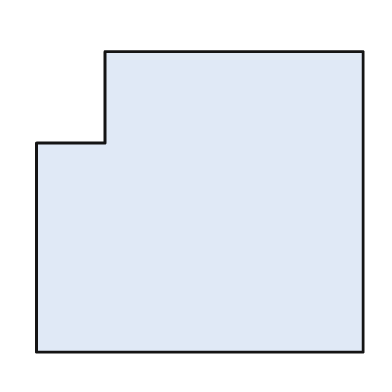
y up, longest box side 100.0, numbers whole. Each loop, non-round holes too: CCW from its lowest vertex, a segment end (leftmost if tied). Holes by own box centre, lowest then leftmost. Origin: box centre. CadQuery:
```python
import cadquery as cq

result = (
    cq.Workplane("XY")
    .moveTo(-50.0, -46.0)
    .lineTo(50.0, -46.0)
    .lineTo(50.0, 46.0)
    .lineTo(-29.0, 46.0)
    .lineTo(-29.0, 18.0)
    .lineTo(-50.0, 18.0)
    .close()
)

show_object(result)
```